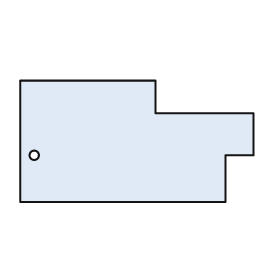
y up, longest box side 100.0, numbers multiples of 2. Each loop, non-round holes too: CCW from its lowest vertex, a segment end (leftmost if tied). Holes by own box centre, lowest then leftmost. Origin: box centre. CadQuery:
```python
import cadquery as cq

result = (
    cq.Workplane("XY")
    .moveTo(-50.0, -26.0)
    .lineTo(38.0, -26.0)
    .lineTo(38.0, -6.0)
    .lineTo(50.0, -6.0)
    .lineTo(50.0, 12.0)
    .lineTo(8.0, 12.0)
    .lineTo(8.0, 26.0)
    .lineTo(-50.0, 26.0)
    .close()
    .moveTo(-44.0, -6.0)
    .circle(2.0)
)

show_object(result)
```